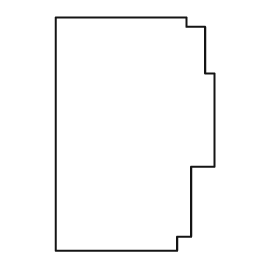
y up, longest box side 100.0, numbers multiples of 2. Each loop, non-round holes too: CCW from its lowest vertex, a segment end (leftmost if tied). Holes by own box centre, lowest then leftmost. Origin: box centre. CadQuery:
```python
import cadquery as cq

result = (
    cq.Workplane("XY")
    .moveTo(-34.0, -50.0)
    .lineTo(18.0, -50.0)
    .lineTo(18.0, -44.0)
    .lineTo(24.0, -44.0)
    .lineTo(24.0, -14.0)
    .lineTo(34.0, -14.0)
    .lineTo(34.0, 26.0)
    .lineTo(30.0, 26.0)
    .lineTo(30.0, 46.0)
    .lineTo(22.0, 46.0)
    .lineTo(22.0, 50.0)
    .lineTo(-34.0, 50.0)
    .close()
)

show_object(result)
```